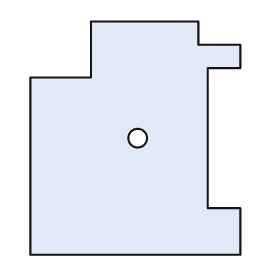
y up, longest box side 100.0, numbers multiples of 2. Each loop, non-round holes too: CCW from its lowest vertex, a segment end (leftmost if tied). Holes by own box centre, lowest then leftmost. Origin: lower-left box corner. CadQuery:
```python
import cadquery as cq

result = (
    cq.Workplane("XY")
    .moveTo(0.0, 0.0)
    .lineTo(90.0, 0.0)
    .lineTo(90.0, 20.0)
    .lineTo(76.0, 20.0)
    .lineTo(76.0, 80.0)
    .lineTo(90.0, 80.0)
    .lineTo(90.0, 90.0)
    .lineTo(72.0, 90.0)
    .lineTo(72.0, 100.0)
    .lineTo(26.0, 100.0)
    .lineTo(26.0, 76.0)
    .lineTo(0.0, 76.0)
    .close()
    .moveTo(46.0, 50.0)
    .circle(4.0)
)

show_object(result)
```